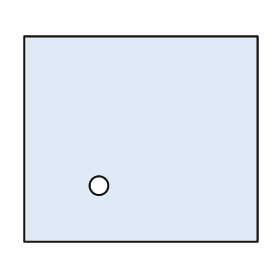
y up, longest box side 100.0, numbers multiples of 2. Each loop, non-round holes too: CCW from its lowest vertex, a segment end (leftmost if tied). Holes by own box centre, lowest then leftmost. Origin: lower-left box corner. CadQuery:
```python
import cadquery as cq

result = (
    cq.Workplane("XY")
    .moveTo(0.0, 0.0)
    .lineTo(100.0, 0.0)
    .lineTo(100.0, 88.0)
    .lineTo(0.0, 88.0)
    .close()
    .moveTo(32.0, 24.0)
    .circle(4.0)
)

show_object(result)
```